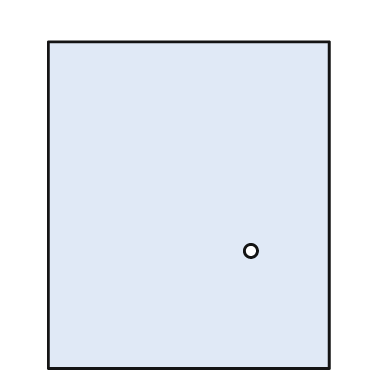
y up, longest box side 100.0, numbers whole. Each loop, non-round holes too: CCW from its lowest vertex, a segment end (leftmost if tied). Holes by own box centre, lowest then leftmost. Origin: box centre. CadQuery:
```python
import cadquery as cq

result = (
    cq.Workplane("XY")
    .moveTo(-43.0, -50.0)
    .lineTo(43.0, -50.0)
    .lineTo(43.0, 50.0)
    .lineTo(-43.0, 50.0)
    .close()
    .moveTo(19.0, -14.0)
    .circle(2.0)
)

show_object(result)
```